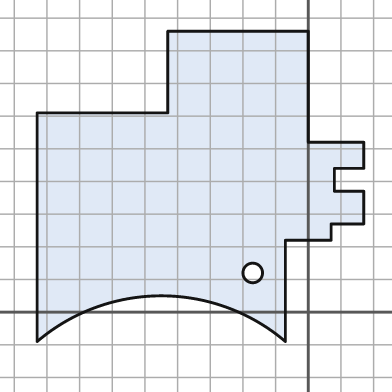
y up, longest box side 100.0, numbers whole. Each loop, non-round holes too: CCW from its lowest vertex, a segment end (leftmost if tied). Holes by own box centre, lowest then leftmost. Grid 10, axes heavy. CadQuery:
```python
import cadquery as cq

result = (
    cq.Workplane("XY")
    .moveTo(-83.0, -9.0)
    .threePointArc((-45.0, 5.0), (-7.0, -9.0))
    .lineTo(-7.0, 22.0)
    .lineTo(7.0, 22.0)
    .lineTo(7.0, 27.0)
    .lineTo(17.0, 27.0)
    .lineTo(17.0, 37.0)
    .lineTo(8.0, 37.0)
    .lineTo(8.0, 44.0)
    .lineTo(17.0, 44.0)
    .lineTo(17.0, 52.0)
    .lineTo(0.0, 52.0)
    .lineTo(0.0, 86.0)
    .lineTo(-43.0, 86.0)
    .lineTo(-43.0, 61.0)
    .lineTo(-83.0, 61.0)
    .close()
    .moveTo(-17.0, 12.0)
    .circle(3.0)
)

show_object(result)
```